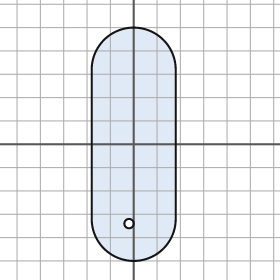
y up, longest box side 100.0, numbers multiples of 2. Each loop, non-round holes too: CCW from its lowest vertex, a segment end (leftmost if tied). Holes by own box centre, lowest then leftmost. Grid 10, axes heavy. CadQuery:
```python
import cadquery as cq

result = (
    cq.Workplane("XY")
    .moveTo(-18.0, -32.0)
    .threePointArc((0.0, -50.0), (18.0, -32.0))
    .lineTo(18.0, 32.0)
    .threePointArc((0.0, 50.0), (-18.0, 32.0))
    .close()
    .moveTo(-2.0, -34.0)
    .circle(2.0)
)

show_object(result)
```